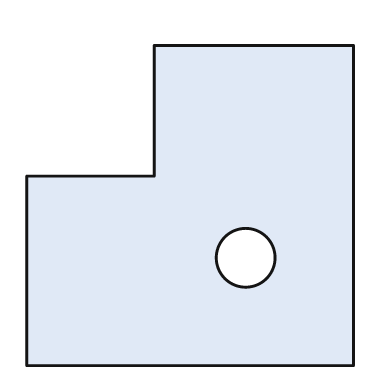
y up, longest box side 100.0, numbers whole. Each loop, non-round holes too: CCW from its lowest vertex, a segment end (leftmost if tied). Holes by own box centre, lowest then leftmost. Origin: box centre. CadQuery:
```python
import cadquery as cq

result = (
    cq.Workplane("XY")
    .moveTo(-50.0, -49.0)
    .lineTo(50.0, -49.0)
    .lineTo(50.0, 49.0)
    .lineTo(-11.0, 49.0)
    .lineTo(-11.0, 9.0)
    .lineTo(-50.0, 9.0)
    .close()
    .moveTo(17.0, -16.0)
    .circle(9.0)
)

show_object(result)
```